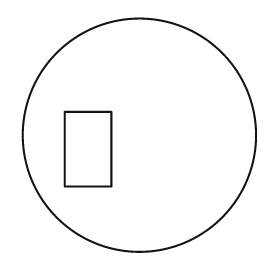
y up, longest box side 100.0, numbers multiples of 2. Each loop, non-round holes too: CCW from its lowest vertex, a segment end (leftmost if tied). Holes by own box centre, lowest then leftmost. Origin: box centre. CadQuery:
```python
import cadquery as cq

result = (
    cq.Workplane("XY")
    .moveTo(0.0, 0.0)
    .circle(50.0)
    .moveTo(-32.0, -22.0)
    .lineTo(-12.0, -22.0)
    .lineTo(-12.0, 10.0)
    .lineTo(-32.0, 10.0)
    .close()
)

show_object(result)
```